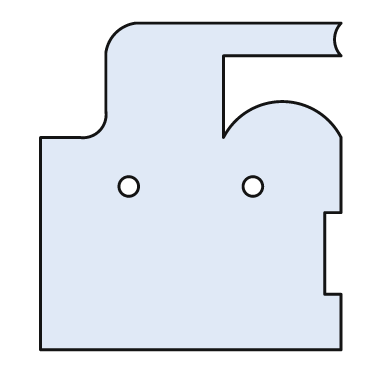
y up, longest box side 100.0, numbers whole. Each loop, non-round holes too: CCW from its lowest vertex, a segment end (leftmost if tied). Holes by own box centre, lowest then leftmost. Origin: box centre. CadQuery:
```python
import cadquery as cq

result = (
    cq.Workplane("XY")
    .moveTo(-46.0, -50.0)
    .lineTo(46.0, -50.0)
    .lineTo(46.0, -33.0)
    .lineTo(41.0, -33.0)
    .lineTo(41.0, -8.0)
    .lineTo(46.0, -8.0)
    .lineTo(46.0, 15.0)
    .threePointArc((28.0, 26.0), (10.0, 15.0))
    .lineTo(10.0, 40.0)
    .lineTo(46.0, 40.0)
    .threePointArc((44.0, 45.0), (46.0, 50.0))
    .lineTo(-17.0, 50.0)
    .threePointArc((-23.0, 47.0), (-26.0, 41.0))
    .lineTo(-26.0, 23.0)
    .threePointArc((-28.0, 17.0), (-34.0, 15.0))
    .lineTo(-46.0, 15.0)
    .close()
    .moveTo(-19.0, 0.0)
    .circle(3.0)
    .moveTo(19.0, 0.0)
    .circle(3.0)
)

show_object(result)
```